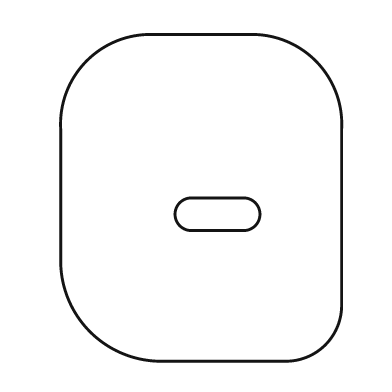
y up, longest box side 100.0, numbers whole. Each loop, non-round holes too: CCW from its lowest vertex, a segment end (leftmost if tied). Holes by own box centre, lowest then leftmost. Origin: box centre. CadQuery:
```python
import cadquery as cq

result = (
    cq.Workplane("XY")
    .moveTo(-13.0, -50.0)
    .lineTo(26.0, -50.0)
    .threePointArc((38.0, -45.0), (43.0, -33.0))
    .lineTo(43.0, 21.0)
    .threePointArc((35.0, 42.0), (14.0, 50.0))
    .lineTo(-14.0, 50.0)
    .threePointArc((-35.0, 42.0), (-43.0, 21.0))
    .lineTo(-43.0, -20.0)
    .threePointArc((-34.0, -41.0), (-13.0, -50.0))
    .close()
    .moveTo(-3.0, -10.0)
    .lineTo(13.0, -10.0)
    .threePointArc((18.0, -5.0), (13.0, 0.0))
    .lineTo(-3.0, 0.0)
    .threePointArc((-8.0, -5.0), (-3.0, -10.0))
    .close()
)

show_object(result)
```